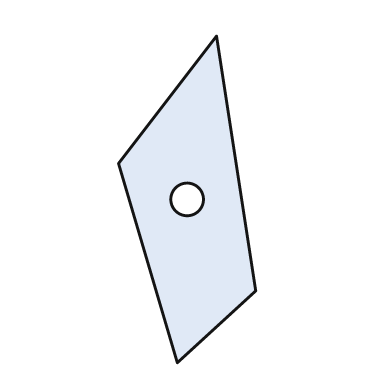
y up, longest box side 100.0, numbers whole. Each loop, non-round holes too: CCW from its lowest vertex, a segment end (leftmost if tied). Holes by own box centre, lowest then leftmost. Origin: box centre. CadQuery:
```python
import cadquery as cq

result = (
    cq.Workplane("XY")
    .moveTo(-3.0, -50.0)
    .lineTo(21.0, -28.0)
    .lineTo(9.0, 50.0)
    .lineTo(-21.0, 11.0)
    .close()
    .moveTo(0.0, 0.0)
    .circle(5.0)
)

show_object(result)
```